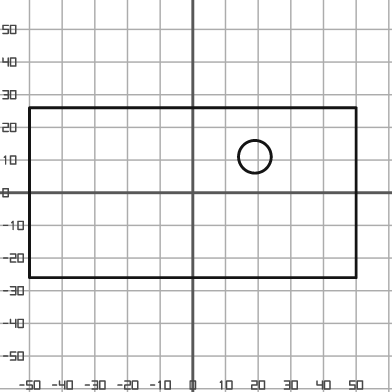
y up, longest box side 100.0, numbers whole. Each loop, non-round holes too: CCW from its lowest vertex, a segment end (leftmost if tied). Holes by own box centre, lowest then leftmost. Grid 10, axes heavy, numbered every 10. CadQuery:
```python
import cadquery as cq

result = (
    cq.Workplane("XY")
    .moveTo(-50.0, -26.0)
    .lineTo(50.0, -26.0)
    .lineTo(50.0, 26.0)
    .lineTo(-50.0, 26.0)
    .close()
    .moveTo(19.0, 11.0)
    .circle(5.0)
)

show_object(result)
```